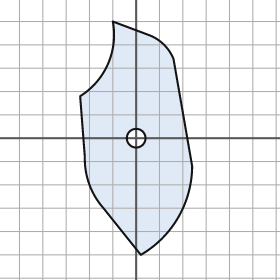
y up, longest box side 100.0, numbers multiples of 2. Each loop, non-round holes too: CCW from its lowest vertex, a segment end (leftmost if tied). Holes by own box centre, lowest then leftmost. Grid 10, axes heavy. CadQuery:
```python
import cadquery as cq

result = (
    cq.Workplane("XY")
    .moveTo(2.0, -50.0)
    .threePointArc((18.0, -34.0), (24.0, -12.0))
    .lineTo(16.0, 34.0)
    .threePointArc((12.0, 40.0), (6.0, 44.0))
    .lineTo(-10.0, 50.0)
    .threePointArc((-12.0, 32.0), (-24.0, 18.0))
    .lineTo(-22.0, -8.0)
    .threePointArc((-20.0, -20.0), (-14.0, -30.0))
    .close()
    .moveTo(0.0, 0.0)
    .circle(4.0)
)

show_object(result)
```